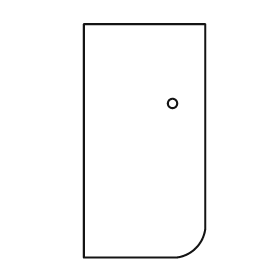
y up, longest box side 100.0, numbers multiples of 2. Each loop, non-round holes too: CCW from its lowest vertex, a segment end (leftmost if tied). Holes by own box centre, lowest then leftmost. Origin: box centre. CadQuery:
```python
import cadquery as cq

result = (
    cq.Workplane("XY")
    .moveTo(-26.0, -50.0)
    .lineTo(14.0, -50.0)
    .threePointArc((22.0, -46.0), (26.0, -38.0))
    .lineTo(26.0, 50.0)
    .lineTo(-26.0, 50.0)
    .close()
    .moveTo(12.0, 16.0)
    .circle(2.0)
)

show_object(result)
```